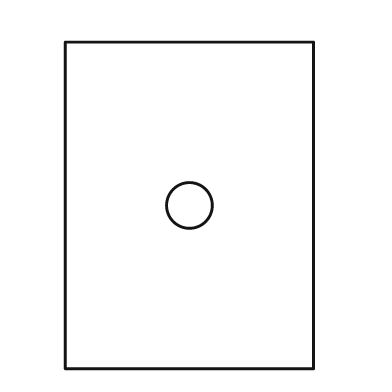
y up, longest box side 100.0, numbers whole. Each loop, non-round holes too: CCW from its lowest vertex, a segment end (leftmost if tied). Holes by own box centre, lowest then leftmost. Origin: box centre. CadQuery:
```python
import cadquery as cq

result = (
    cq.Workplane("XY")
    .moveTo(-38.0, -50.0)
    .lineTo(38.0, -50.0)
    .lineTo(38.0, 50.0)
    .lineTo(-38.0, 50.0)
    .close()
    .moveTo(0.0, 0.0)
    .circle(7.0)
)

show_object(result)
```